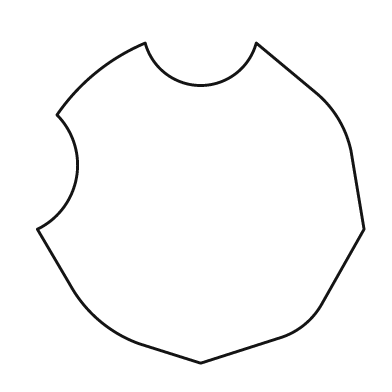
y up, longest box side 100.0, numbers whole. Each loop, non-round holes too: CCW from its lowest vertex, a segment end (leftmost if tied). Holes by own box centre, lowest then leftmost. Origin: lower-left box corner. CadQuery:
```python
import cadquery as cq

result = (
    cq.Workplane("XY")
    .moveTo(50.0, 0.0)
    .lineTo(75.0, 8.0)
    .threePointArc((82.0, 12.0), (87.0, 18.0))
    .lineTo(100.0, 41.0)
    .lineTo(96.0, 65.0)
    .threePointArc((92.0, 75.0), (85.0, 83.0))
    .lineTo(67.0, 98.0)
    .threePointArc((50.0, 85.0), (33.0, 98.0))
    .threePointArc((18.0, 89.0), (6.0, 76.0))
    .threePointArc((12.0, 57.0), (0.0, 41.0))
    .lineTo(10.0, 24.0)
    .threePointArc((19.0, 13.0), (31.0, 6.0))
    .close()
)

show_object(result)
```